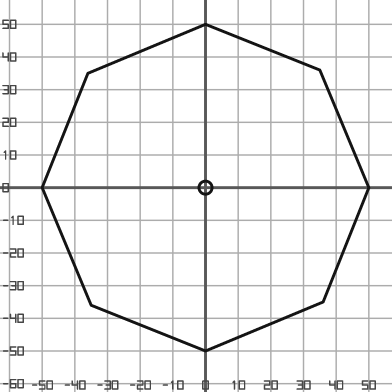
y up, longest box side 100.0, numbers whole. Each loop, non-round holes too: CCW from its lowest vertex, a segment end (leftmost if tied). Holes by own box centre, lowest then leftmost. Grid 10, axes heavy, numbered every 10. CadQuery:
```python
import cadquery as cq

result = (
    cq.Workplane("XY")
    .moveTo(0.0, -50.0)
    .lineTo(36.0, -35.0)
    .lineTo(50.0, 0.0)
    .lineTo(35.0, 36.0)
    .lineTo(0.0, 50.0)
    .lineTo(-36.0, 35.0)
    .lineTo(-50.0, 0.0)
    .lineTo(-35.0, -36.0)
    .close()
    .moveTo(0.0, 0.0)
    .circle(2.0)
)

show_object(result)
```